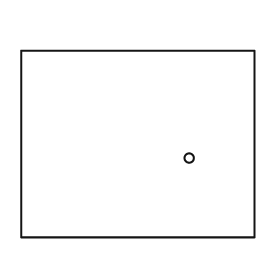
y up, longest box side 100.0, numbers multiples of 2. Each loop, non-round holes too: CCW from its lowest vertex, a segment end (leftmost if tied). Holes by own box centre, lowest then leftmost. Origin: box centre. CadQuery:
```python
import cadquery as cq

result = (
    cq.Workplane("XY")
    .moveTo(-50.0, -40.0)
    .lineTo(50.0, -40.0)
    .lineTo(50.0, 40.0)
    .lineTo(-50.0, 40.0)
    .close()
    .moveTo(22.0, -6.0)
    .circle(2.0)
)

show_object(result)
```